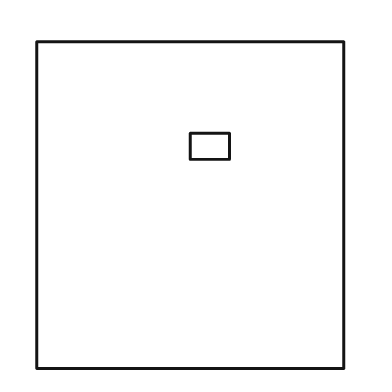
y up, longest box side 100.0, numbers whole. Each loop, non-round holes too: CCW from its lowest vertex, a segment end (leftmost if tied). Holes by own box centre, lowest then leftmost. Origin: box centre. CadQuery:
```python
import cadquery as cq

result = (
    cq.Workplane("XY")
    .moveTo(-47.0, -50.0)
    .lineTo(47.0, -50.0)
    .lineTo(47.0, 50.0)
    .lineTo(-47.0, 50.0)
    .close()
    .moveTo(0.0, 14.0)
    .lineTo(12.0, 14.0)
    .lineTo(12.0, 22.0)
    .lineTo(0.0, 22.0)
    .close()
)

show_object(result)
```